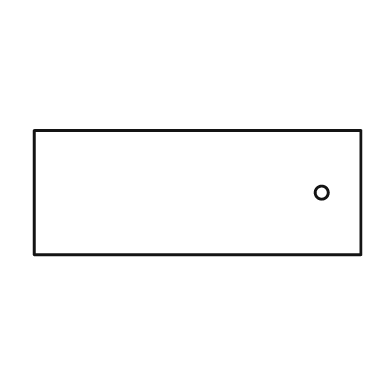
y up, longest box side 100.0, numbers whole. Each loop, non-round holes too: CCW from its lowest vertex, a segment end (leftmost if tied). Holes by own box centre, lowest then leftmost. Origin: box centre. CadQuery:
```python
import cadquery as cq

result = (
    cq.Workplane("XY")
    .moveTo(-50.0, -19.0)
    .lineTo(50.0, -19.0)
    .lineTo(50.0, 19.0)
    .lineTo(-50.0, 19.0)
    .close()
    .moveTo(38.0, 0.0)
    .circle(2.0)
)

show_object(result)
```